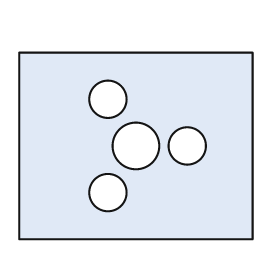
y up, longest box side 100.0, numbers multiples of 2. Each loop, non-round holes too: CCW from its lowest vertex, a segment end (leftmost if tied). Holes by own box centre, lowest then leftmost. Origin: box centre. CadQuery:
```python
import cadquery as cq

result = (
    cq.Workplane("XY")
    .moveTo(-50.0, -40.0)
    .lineTo(50.0, -40.0)
    .lineTo(50.0, 40.0)
    .lineTo(-50.0, 40.0)
    .close()
    .moveTo(-12.0, -20.0)
    .circle(8.0)
    .moveTo(0.0, 0.0)
    .circle(10.0)
    .moveTo(22.0, 0.0)
    .circle(8.0)
    .moveTo(-12.0, 20.0)
    .circle(8.0)
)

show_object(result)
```